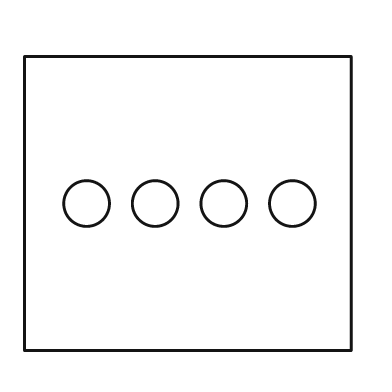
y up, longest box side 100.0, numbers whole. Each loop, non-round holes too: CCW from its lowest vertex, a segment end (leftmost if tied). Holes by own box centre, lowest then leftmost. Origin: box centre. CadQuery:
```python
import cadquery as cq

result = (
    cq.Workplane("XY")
    .moveTo(-50.0, -45.0)
    .lineTo(50.0, -45.0)
    .lineTo(50.0, 45.0)
    .lineTo(-50.0, 45.0)
    .close()
    .moveTo(-31.0, 0.0)
    .circle(7.0)
    .moveTo(-10.0, 0.0)
    .circle(7.0)
    .moveTo(11.0, 0.0)
    .circle(7.0)
    .moveTo(32.0, 0.0)
    .circle(7.0)
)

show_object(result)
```